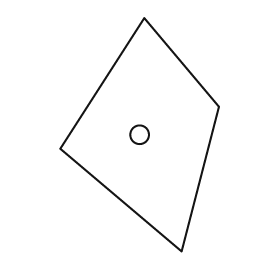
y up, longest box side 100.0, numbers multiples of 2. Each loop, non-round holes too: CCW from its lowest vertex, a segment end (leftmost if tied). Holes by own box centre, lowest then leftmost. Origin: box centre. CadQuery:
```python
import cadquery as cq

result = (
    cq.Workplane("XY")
    .moveTo(18.0, -50.0)
    .lineTo(34.0, 12.0)
    .lineTo(2.0, 50.0)
    .lineTo(-34.0, -6.0)
    .close()
    .moveTo(0.0, 0.0)
    .circle(4.0)
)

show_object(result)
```